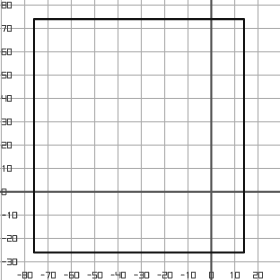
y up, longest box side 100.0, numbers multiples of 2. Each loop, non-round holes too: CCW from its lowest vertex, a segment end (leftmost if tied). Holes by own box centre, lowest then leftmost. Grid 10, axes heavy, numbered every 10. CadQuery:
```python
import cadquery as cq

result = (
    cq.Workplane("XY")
    .moveTo(-76.0, -26.0)
    .lineTo(14.0, -26.0)
    .lineTo(14.0, 74.0)
    .lineTo(-76.0, 74.0)
    .close()
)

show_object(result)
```